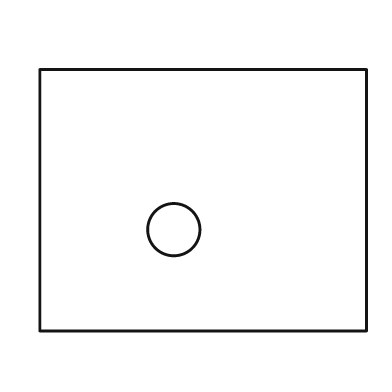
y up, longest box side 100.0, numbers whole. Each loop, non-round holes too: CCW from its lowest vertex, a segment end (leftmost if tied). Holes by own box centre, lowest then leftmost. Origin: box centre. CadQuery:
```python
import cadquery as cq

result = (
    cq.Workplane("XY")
    .moveTo(-50.0, -40.0)
    .lineTo(50.0, -40.0)
    .lineTo(50.0, 40.0)
    .lineTo(-50.0, 40.0)
    .close()
    .moveTo(-9.0, -9.0)
    .circle(8.0)
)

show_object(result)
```